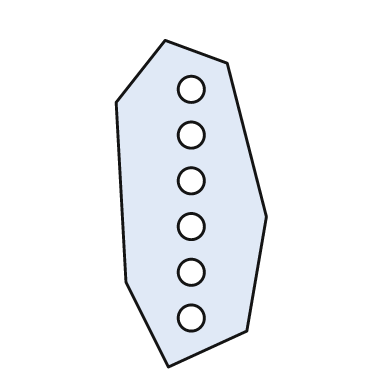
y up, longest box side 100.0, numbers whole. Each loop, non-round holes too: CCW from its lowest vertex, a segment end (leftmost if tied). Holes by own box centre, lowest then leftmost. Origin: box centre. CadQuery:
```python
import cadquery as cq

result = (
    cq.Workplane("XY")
    .moveTo(-7.0, -50.0)
    .lineTo(17.0, -39.0)
    .lineTo(23.0, -4.0)
    .lineTo(11.0, 43.0)
    .lineTo(-8.0, 50.0)
    .lineTo(-23.0, 31.0)
    .lineTo(-20.0, -24.0)
    .close()
    .moveTo(0.0, -35.0)
    .circle(4.0)
    .moveTo(0.0, -21.0)
    .circle(4.0)
    .moveTo(0.0, -7.0)
    .circle(4.0)
    .moveTo(0.0, 7.0)
    .circle(4.0)
    .moveTo(0.0, 21.0)
    .circle(4.0)
    .moveTo(0.0, 35.0)
    .circle(4.0)
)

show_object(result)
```